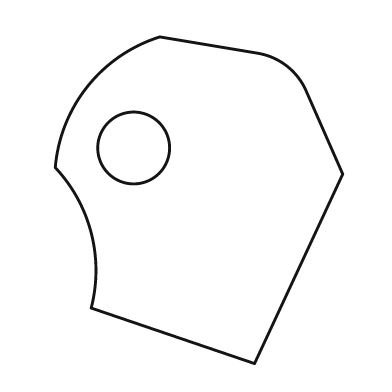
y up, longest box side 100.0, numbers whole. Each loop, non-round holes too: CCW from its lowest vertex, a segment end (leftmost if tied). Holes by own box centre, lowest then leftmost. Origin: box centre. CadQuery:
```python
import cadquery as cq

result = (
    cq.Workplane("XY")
    .moveTo(17.0, -50.0)
    .lineTo(44.0, 8.0)
    .lineTo(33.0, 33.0)
    .threePointArc((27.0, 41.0), (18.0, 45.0))
    .lineTo(-12.0, 50.0)
    .threePointArc((-34.0, 35.0), (-44.0, 10.0))
    .threePointArc((-33.0, -10.0), (-33.0, -33.0))
    .close()
    .moveTo(-20.0, 16.0)
    .circle(11.0)
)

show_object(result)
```